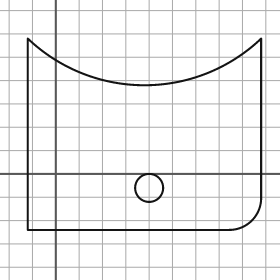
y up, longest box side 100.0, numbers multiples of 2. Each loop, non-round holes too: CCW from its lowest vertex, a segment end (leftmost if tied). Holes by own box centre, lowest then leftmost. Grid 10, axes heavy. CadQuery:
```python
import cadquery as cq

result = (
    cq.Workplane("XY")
    .moveTo(-12.0, -24.0)
    .lineTo(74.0, -24.0)
    .threePointArc((84.0, -20.0), (88.0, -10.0))
    .lineTo(88.0, 58.0)
    .threePointArc((38.0, 38.0), (-12.0, 58.0))
    .close()
    .moveTo(40.0, -6.0)
    .circle(6.0)
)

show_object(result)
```